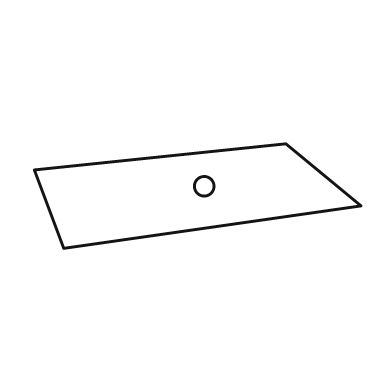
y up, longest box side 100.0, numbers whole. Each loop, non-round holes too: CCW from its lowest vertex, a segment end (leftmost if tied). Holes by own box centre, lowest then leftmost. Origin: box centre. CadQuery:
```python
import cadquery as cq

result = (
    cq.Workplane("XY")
    .moveTo(-41.0, -16.0)
    .lineTo(50.0, -3.0)
    .lineTo(27.0, 16.0)
    .lineTo(-50.0, 8.0)
    .close()
    .moveTo(2.0, 3.0)
    .circle(3.0)
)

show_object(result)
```